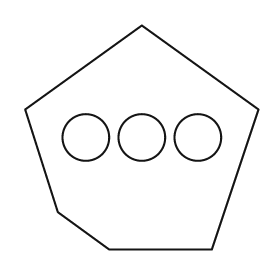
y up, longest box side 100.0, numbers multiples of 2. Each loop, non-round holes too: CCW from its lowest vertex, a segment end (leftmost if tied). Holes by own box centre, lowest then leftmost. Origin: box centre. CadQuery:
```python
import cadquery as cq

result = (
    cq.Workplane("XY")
    .moveTo(-14.0, -48.0)
    .lineTo(30.0, -48.0)
    .lineTo(50.0, 12.0)
    .lineTo(0.0, 48.0)
    .lineTo(-50.0, 12.0)
    .lineTo(-36.0, -32.0)
    .close()
    .moveTo(-24.0, 0.0)
    .circle(10.0)
    .moveTo(0.0, 0.0)
    .circle(10.0)
    .moveTo(24.0, 0.0)
    .circle(10.0)
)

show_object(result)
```